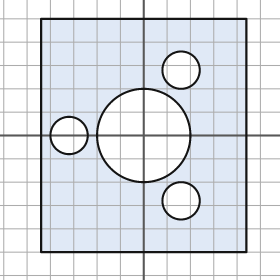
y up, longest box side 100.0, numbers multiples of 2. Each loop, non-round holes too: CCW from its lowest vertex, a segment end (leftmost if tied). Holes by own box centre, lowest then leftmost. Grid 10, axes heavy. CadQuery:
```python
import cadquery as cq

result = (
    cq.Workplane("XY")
    .moveTo(-44.0, -50.0)
    .lineTo(44.0, -50.0)
    .lineTo(44.0, 50.0)
    .lineTo(-44.0, 50.0)
    .close()
    .moveTo(16.0, -28.0)
    .circle(8.0)
    .moveTo(-32.0, 0.0)
    .circle(8.0)
    .moveTo(0.0, 0.0)
    .circle(20.0)
    .moveTo(16.0, 28.0)
    .circle(8.0)
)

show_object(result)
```